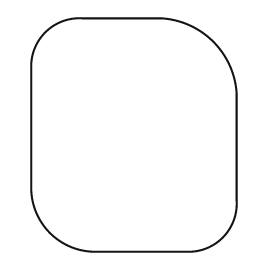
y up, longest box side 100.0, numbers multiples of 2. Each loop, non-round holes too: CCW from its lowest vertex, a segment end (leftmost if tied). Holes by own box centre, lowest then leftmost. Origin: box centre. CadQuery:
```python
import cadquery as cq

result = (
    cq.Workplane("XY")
    .moveTo(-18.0, -50.0)
    .lineTo(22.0, -50.0)
    .threePointArc((38.0, -44.0), (44.0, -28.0))
    .lineTo(44.0, 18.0)
    .threePointArc((34.0, 40.0), (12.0, 50.0))
    .lineTo(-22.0, 50.0)
    .threePointArc((-38.0, 44.0), (-44.0, 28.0))
    .lineTo(-44.0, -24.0)
    .threePointArc((-36.0, -42.0), (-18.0, -50.0))
    .close()
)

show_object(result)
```